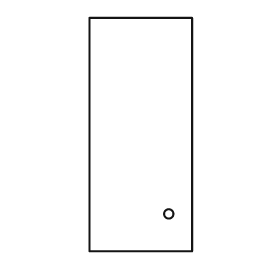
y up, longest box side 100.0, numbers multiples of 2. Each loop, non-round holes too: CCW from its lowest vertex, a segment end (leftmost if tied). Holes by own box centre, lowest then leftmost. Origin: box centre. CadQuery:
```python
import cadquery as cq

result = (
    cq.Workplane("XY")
    .moveTo(-22.0, -50.0)
    .lineTo(22.0, -50.0)
    .lineTo(22.0, 50.0)
    .lineTo(-22.0, 50.0)
    .close()
    .moveTo(12.0, -34.0)
    .circle(2.0)
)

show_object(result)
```